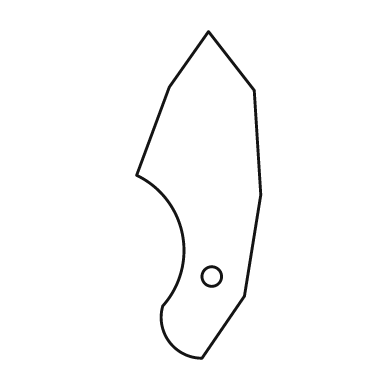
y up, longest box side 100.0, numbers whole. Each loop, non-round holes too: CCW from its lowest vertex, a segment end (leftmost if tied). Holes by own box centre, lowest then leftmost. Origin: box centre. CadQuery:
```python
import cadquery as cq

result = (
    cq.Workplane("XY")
    .moveTo(1.0, -50.0)
    .lineTo(14.0, -31.0)
    .lineTo(19.0, 0.0)
    .lineTo(17.0, 32.0)
    .lineTo(3.0, 50.0)
    .lineTo(-9.0, 33.0)
    .lineTo(-19.0, 6.0)
    .threePointArc((-5.0, -12.0), (-11.0, -34.0))
    .threePointArc((-9.0, -45.0), (1.0, -50.0))
    .close()
    .moveTo(4.0, -25.0)
    .circle(3.0)
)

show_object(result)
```